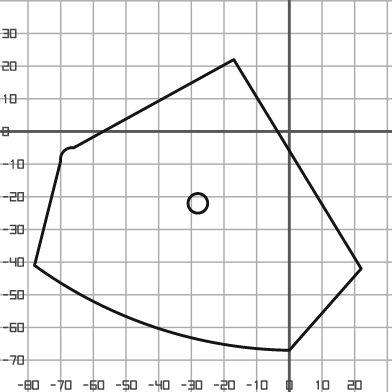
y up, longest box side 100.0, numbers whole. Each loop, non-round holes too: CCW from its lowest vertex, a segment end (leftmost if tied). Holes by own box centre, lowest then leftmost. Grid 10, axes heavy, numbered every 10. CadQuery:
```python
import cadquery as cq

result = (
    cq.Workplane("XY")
    .moveTo(0.0, -67.0)
    .lineTo(22.0, -42.0)
    .lineTo(-17.0, 22.0)
    .lineTo(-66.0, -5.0)
    .threePointArc((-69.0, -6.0), (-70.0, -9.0))
    .lineTo(-78.0, -41.0)
    .threePointArc((-41.0, -60.0), (0.0, -67.0))
    .close()
    .moveTo(-28.0, -22.0)
    .circle(3.0)
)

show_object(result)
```